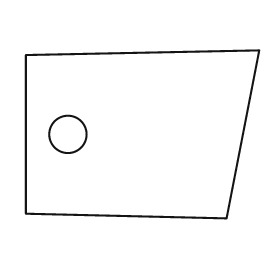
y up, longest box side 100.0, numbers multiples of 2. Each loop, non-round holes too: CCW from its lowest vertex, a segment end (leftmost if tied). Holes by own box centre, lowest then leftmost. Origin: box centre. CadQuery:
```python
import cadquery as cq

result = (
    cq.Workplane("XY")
    .moveTo(36.0, -36.0)
    .lineTo(50.0, 36.0)
    .lineTo(-50.0, 34.0)
    .lineTo(-50.0, -34.0)
    .close()
    .moveTo(-32.0, 0.0)
    .circle(8.0)
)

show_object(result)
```